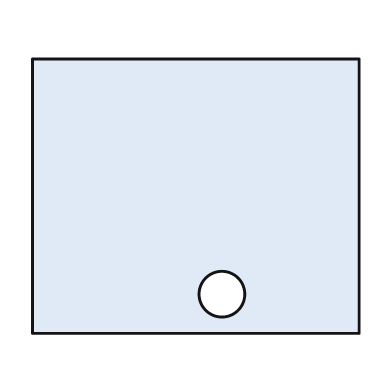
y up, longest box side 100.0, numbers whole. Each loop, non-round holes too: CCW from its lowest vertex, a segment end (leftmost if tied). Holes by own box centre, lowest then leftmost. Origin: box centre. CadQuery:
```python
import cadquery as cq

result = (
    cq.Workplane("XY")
    .moveTo(-50.0, -42.0)
    .lineTo(50.0, -42.0)
    .lineTo(50.0, 42.0)
    .lineTo(-50.0, 42.0)
    .close()
    .moveTo(8.0, -30.0)
    .circle(7.0)
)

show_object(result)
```